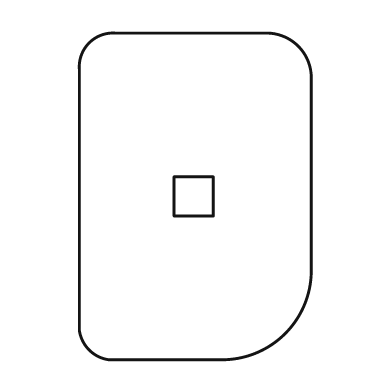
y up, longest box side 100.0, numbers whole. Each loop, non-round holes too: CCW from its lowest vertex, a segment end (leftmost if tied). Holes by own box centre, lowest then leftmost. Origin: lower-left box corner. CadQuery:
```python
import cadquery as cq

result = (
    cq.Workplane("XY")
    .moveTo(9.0, 0.0)
    .lineTo(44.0, 0.0)
    .threePointArc((63.0, 8.0), (71.0, 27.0))
    .lineTo(71.0, 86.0)
    .threePointArc((67.0, 96.0), (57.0, 100.0))
    .lineTo(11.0, 100.0)
    .threePointArc((3.0, 97.0), (0.0, 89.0))
    .lineTo(0.0, 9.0)
    .threePointArc((3.0, 3.0), (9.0, 0.0))
    .close()
    .moveTo(29.0, 44.0)
    .lineTo(41.0, 44.0)
    .lineTo(41.0, 56.0)
    .lineTo(29.0, 56.0)
    .close()
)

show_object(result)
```